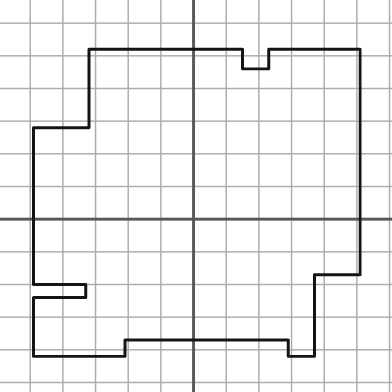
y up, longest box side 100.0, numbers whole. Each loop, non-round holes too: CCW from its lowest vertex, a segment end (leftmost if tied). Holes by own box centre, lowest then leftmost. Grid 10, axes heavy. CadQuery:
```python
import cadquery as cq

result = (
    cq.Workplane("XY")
    .moveTo(-49.0, -42.0)
    .lineTo(-21.0, -42.0)
    .lineTo(-21.0, -37.0)
    .lineTo(29.0, -37.0)
    .lineTo(29.0, -42.0)
    .lineTo(37.0, -42.0)
    .lineTo(37.0, -17.0)
    .lineTo(51.0, -17.0)
    .lineTo(51.0, 52.0)
    .lineTo(23.0, 52.0)
    .lineTo(23.0, 46.0)
    .lineTo(15.0, 46.0)
    .lineTo(15.0, 52.0)
    .lineTo(-32.0, 52.0)
    .lineTo(-32.0, 28.0)
    .lineTo(-49.0, 28.0)
    .lineTo(-49.0, -20.0)
    .lineTo(-33.0, -20.0)
    .lineTo(-33.0, -24.0)
    .lineTo(-49.0, -24.0)
    .close()
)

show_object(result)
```